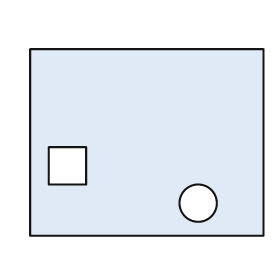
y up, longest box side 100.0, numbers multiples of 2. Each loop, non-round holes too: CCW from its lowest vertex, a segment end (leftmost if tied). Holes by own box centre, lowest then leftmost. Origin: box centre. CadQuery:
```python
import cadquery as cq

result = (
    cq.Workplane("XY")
    .moveTo(-50.0, -40.0)
    .lineTo(50.0, -40.0)
    .lineTo(50.0, 40.0)
    .lineTo(-50.0, 40.0)
    .close()
    .moveTo(22.0, -26.0)
    .circle(8.0)
    .moveTo(-42.0, -18.0)
    .lineTo(-26.0, -18.0)
    .lineTo(-26.0, -2.0)
    .lineTo(-42.0, -2.0)
    .close()
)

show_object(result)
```